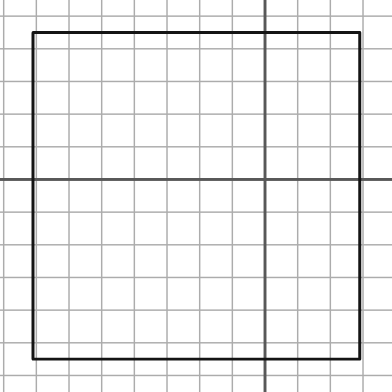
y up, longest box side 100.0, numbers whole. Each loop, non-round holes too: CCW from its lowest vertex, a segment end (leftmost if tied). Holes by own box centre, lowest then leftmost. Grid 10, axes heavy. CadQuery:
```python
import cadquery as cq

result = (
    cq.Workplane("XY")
    .moveTo(-71.0, -55.0)
    .lineTo(29.0, -55.0)
    .lineTo(29.0, 45.0)
    .lineTo(-71.0, 45.0)
    .close()
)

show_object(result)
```